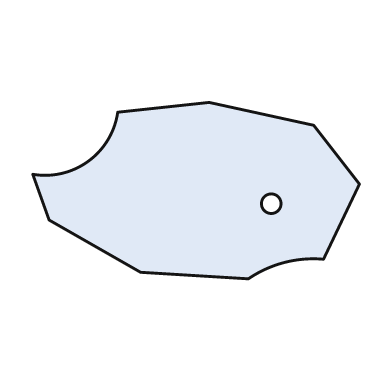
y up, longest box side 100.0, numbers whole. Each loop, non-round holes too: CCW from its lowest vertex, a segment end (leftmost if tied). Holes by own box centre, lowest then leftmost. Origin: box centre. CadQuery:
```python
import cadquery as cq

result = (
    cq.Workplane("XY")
    .moveTo(16.0, -27.0)
    .threePointArc((27.0, -22.0), (39.0, -21.0))
    .lineTo(50.0, 2.0)
    .lineTo(36.0, 20.0)
    .lineTo(4.0, 27.0)
    .lineTo(-24.0, 24.0)
    .threePointArc((-33.0, 9.0), (-50.0, 5.0))
    .lineTo(-45.0, -9.0)
    .lineTo(-17.0, -25.0)
    .close()
    .moveTo(23.0, -4.0)
    .circle(3.0)
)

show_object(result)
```